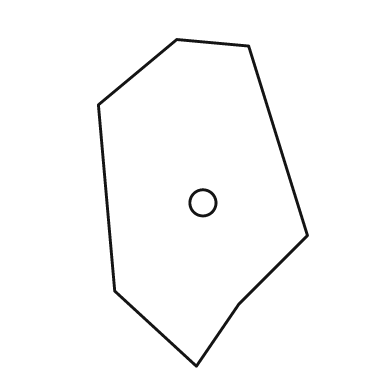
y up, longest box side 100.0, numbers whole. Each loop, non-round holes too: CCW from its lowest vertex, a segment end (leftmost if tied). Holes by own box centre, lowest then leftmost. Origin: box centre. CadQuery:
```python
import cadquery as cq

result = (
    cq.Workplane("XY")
    .moveTo(-2.0, -50.0)
    .lineTo(11.0, -31.0)
    .lineTo(32.0, -10.0)
    .lineTo(14.0, 48.0)
    .lineTo(-8.0, 50.0)
    .lineTo(-32.0, 30.0)
    .lineTo(-27.0, -27.0)
    .close()
    .moveTo(0.0, 0.0)
    .circle(4.0)
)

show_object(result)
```